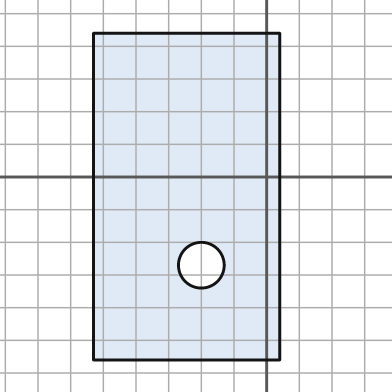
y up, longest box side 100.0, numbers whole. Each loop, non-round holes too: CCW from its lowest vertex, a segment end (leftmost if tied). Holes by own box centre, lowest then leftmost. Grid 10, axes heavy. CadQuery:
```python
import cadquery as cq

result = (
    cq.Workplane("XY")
    .moveTo(-53.0, -56.0)
    .lineTo(4.0, -56.0)
    .lineTo(4.0, 44.0)
    .lineTo(-53.0, 44.0)
    .close()
    .moveTo(-20.0, -27.0)
    .circle(7.0)
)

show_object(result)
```